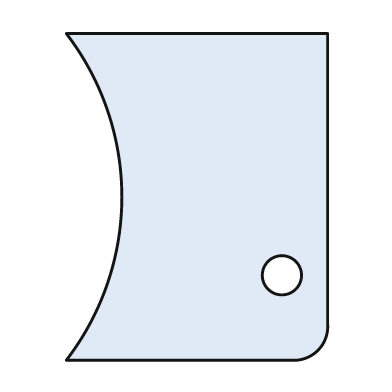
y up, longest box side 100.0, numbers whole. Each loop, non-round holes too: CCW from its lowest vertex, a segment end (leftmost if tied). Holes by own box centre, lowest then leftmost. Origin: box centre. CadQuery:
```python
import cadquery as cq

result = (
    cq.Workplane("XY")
    .moveTo(-40.0, -50.0)
    .lineTo(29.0, -50.0)
    .threePointArc((37.0, -47.0), (40.0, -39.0))
    .lineTo(40.0, 50.0)
    .lineTo(-40.0, 50.0)
    .threePointArc((-23.0, 0.0), (-40.0, -50.0))
    .close()
    .moveTo(26.0, -24.0)
    .circle(6.0)
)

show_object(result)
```